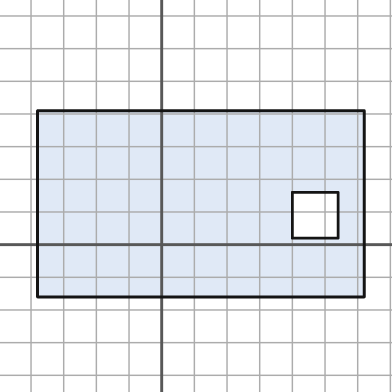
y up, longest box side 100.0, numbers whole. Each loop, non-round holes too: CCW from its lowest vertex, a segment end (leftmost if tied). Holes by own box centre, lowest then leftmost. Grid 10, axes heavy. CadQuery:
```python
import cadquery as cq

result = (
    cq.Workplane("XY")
    .moveTo(-38.0, -16.0)
    .lineTo(62.0, -16.0)
    .lineTo(62.0, 41.0)
    .lineTo(-38.0, 41.0)
    .close()
    .moveTo(40.0, 2.0)
    .lineTo(54.0, 2.0)
    .lineTo(54.0, 16.0)
    .lineTo(40.0, 16.0)
    .close()
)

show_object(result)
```